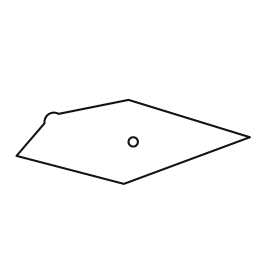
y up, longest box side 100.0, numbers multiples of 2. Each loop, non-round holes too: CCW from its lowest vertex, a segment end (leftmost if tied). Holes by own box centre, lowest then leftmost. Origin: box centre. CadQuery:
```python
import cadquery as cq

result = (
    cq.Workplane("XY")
    .moveTo(-4.0, -18.0)
    .lineTo(50.0, 2.0)
    .lineTo(-2.0, 18.0)
    .lineTo(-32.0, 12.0)
    .threePointArc((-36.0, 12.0), (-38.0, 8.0))
    .lineTo(-50.0, -6.0)
    .close()
    .moveTo(0.0, 0.0)
    .circle(2.0)
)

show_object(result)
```